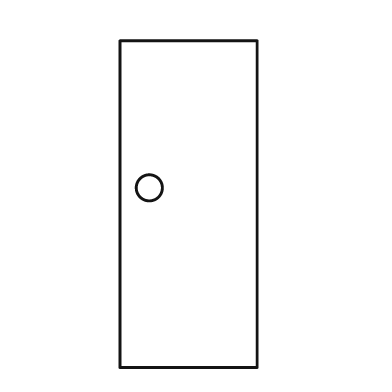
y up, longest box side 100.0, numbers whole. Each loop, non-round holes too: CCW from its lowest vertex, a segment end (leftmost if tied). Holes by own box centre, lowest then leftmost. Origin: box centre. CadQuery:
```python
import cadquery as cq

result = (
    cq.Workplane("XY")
    .moveTo(-21.0, -50.0)
    .lineTo(21.0, -50.0)
    .lineTo(21.0, 50.0)
    .lineTo(-21.0, 50.0)
    .close()
    .moveTo(-12.0, 5.0)
    .circle(4.0)
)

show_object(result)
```